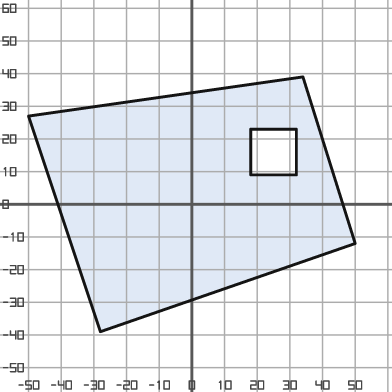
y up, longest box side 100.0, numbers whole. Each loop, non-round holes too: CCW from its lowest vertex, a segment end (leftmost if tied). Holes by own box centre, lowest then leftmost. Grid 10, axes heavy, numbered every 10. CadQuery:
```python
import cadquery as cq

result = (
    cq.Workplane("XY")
    .moveTo(-28.0, -39.0)
    .lineTo(50.0, -12.0)
    .lineTo(34.0, 39.0)
    .lineTo(-50.0, 27.0)
    .close()
    .moveTo(18.0, 9.0)
    .lineTo(32.0, 9.0)
    .lineTo(32.0, 23.0)
    .lineTo(18.0, 23.0)
    .close()
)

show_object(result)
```